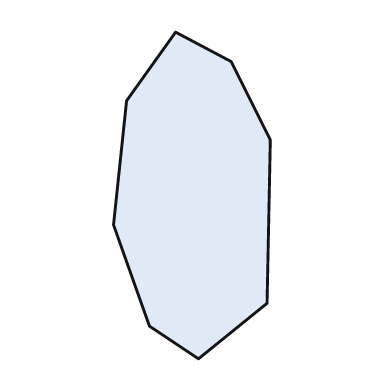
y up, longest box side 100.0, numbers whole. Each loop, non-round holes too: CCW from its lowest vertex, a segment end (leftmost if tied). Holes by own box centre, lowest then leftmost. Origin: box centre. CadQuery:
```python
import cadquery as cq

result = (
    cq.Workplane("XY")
    .moveTo(2.0, -50.0)
    .lineTo(23.0, -33.0)
    .lineTo(24.0, 17.0)
    .lineTo(12.0, 41.0)
    .lineTo(-5.0, 50.0)
    .lineTo(-20.0, 29.0)
    .lineTo(-24.0, -9.0)
    .lineTo(-13.0, -40.0)
    .close()
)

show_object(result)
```